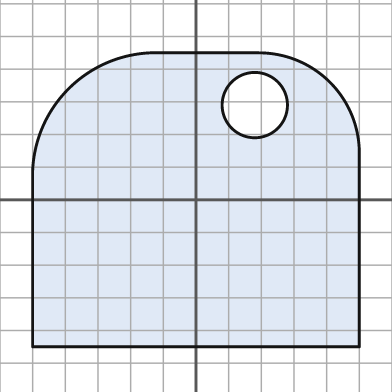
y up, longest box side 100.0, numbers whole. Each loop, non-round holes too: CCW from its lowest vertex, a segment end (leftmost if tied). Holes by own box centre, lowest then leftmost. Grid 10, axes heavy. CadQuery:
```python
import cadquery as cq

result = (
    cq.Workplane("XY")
    .moveTo(-50.0, -45.0)
    .lineTo(50.0, -45.0)
    .lineTo(50.0, 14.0)
    .threePointArc((41.0, 36.0), (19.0, 45.0))
    .lineTo(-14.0, 45.0)
    .threePointArc((-39.0, 34.0), (-50.0, 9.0))
    .close()
    .moveTo(18.0, 29.0)
    .circle(10.0)
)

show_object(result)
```